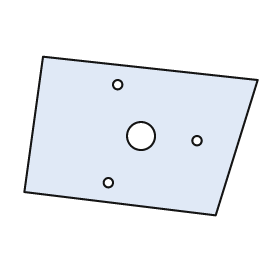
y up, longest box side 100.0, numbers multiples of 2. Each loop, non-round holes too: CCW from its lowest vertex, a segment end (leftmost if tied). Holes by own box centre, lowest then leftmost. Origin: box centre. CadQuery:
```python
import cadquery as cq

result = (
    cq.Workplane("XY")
    .moveTo(32.0, -34.0)
    .lineTo(50.0, 24.0)
    .lineTo(-42.0, 34.0)
    .lineTo(-50.0, -24.0)
    .close()
    .moveTo(-14.0, -20.0)
    .circle(2.0)
    .moveTo(24.0, -2.0)
    .circle(2.0)
    .moveTo(0.0, 0.0)
    .circle(6.0)
    .moveTo(-10.0, 22.0)
    .circle(2.0)
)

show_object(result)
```